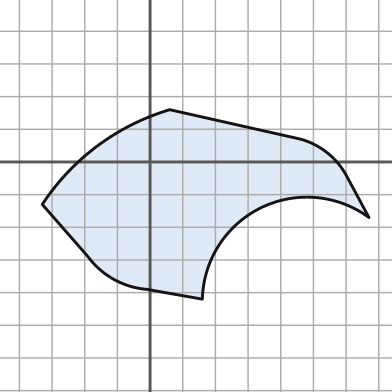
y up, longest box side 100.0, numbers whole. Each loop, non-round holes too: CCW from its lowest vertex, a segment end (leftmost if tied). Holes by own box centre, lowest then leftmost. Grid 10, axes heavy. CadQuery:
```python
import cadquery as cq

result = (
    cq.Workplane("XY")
    .moveTo(16.0, -42.0)
    .threePointArc((34.0, -14.0), (67.0, -17.0))
    .lineTo(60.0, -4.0)
    .threePointArc((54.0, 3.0), (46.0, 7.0))
    .lineTo(6.0, 16.0)
    .threePointArc((-16.0, 5.0), (-33.0, -13.0))
    .lineTo(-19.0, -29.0)
    .threePointArc((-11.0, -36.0), (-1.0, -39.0))
    .close()
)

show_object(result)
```